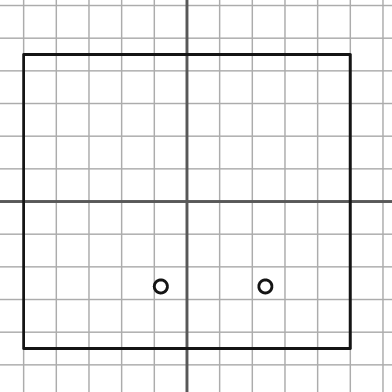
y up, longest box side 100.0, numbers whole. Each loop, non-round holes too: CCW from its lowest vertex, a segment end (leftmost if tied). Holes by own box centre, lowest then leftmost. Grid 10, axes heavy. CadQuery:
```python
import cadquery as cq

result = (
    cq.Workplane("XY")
    .moveTo(-50.0, -45.0)
    .lineTo(50.0, -45.0)
    .lineTo(50.0, 45.0)
    .lineTo(-50.0, 45.0)
    .close()
    .moveTo(-8.0, -26.0)
    .circle(2.0)
    .moveTo(24.0, -26.0)
    .circle(2.0)
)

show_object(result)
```